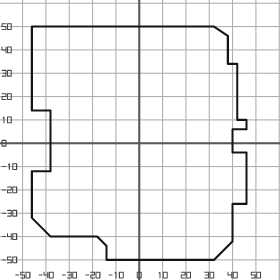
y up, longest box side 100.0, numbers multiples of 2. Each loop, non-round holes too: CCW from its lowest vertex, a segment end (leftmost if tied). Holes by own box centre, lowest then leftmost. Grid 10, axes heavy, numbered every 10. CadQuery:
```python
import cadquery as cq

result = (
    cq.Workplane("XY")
    .moveTo(-14.0, -50.0)
    .lineTo(32.0, -50.0)
    .lineTo(40.0, -42.0)
    .lineTo(40.0, -26.0)
    .lineTo(46.0, -26.0)
    .lineTo(46.0, -4.0)
    .lineTo(40.0, -4.0)
    .lineTo(40.0, 6.0)
    .lineTo(46.0, 6.0)
    .lineTo(46.0, 10.0)
    .lineTo(42.0, 10.0)
    .lineTo(42.0, 34.0)
    .lineTo(38.0, 34.0)
    .lineTo(38.0, 46.0)
    .lineTo(32.0, 50.0)
    .lineTo(-46.0, 50.0)
    .lineTo(-46.0, 14.0)
    .lineTo(-38.0, 14.0)
    .lineTo(-38.0, -12.0)
    .lineTo(-46.0, -12.0)
    .lineTo(-46.0, -32.0)
    .lineTo(-38.0, -40.0)
    .lineTo(-18.0, -40.0)
    .lineTo(-14.0, -44.0)
    .close()
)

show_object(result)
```